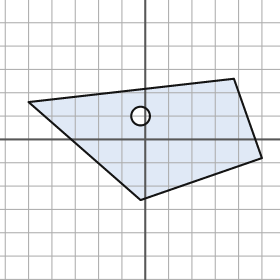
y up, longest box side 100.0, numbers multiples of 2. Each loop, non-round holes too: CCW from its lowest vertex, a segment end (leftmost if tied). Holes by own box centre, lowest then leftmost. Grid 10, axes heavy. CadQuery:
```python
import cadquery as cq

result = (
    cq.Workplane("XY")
    .moveTo(-2.0, -26.0)
    .lineTo(50.0, -8.0)
    .lineTo(38.0, 26.0)
    .lineTo(-50.0, 16.0)
    .close()
    .moveTo(-2.0, 10.0)
    .circle(4.0)
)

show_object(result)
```